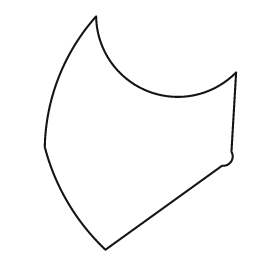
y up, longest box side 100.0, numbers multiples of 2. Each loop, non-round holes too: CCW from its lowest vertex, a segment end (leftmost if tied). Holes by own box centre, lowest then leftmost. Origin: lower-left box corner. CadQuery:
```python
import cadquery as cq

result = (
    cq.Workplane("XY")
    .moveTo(26.0, 0.0)
    .lineTo(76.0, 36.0)
    .threePointArc((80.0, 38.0), (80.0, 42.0))
    .lineTo(82.0, 76.0)
    .threePointArc((44.0, 68.0), (22.0, 100.0))
    .threePointArc((6.0, 74.0), (0.0, 44.0))
    .threePointArc((10.0, 20.0), (26.0, 0.0))
    .close()
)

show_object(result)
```